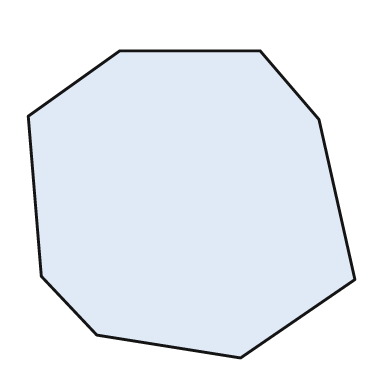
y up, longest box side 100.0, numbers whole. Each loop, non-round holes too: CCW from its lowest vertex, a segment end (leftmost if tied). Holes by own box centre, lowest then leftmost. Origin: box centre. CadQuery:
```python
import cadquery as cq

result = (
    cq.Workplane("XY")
    .moveTo(15.0, -47.0)
    .lineTo(50.0, -23.0)
    .lineTo(39.0, 26.0)
    .lineTo(21.0, 47.0)
    .lineTo(-22.0, 47.0)
    .lineTo(-50.0, 27.0)
    .lineTo(-46.0, -22.0)
    .lineTo(-29.0, -40.0)
    .close()
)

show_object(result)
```